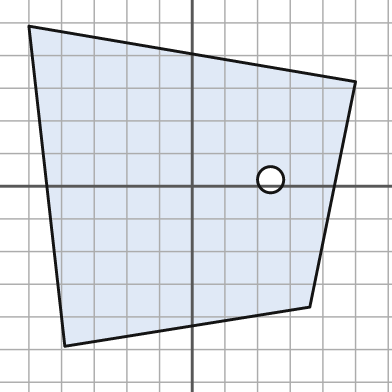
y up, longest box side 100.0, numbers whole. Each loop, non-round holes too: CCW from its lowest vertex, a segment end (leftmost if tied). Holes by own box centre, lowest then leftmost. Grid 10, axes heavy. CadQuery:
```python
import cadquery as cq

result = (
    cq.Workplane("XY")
    .moveTo(-39.0, -49.0)
    .lineTo(36.0, -37.0)
    .lineTo(50.0, 32.0)
    .lineTo(-50.0, 49.0)
    .close()
    .moveTo(24.0, 2.0)
    .circle(4.0)
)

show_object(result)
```